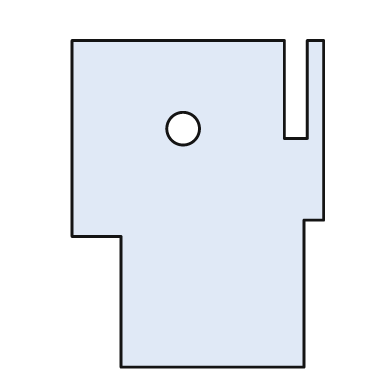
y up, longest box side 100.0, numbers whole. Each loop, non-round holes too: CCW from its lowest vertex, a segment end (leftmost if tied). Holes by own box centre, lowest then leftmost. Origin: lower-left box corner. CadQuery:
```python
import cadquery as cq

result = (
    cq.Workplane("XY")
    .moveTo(15.0, 0.0)
    .lineTo(71.0, 0.0)
    .lineTo(71.0, 45.0)
    .lineTo(77.0, 45.0)
    .lineTo(77.0, 100.0)
    .lineTo(72.0, 100.0)
    .lineTo(72.0, 70.0)
    .lineTo(65.0, 70.0)
    .lineTo(65.0, 100.0)
    .lineTo(0.0, 100.0)
    .lineTo(0.0, 40.0)
    .lineTo(15.0, 40.0)
    .close()
    .moveTo(34.0, 73.0)
    .circle(5.0)
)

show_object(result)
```